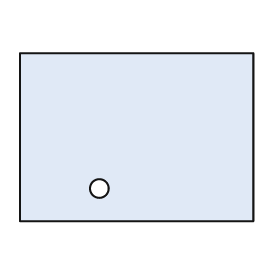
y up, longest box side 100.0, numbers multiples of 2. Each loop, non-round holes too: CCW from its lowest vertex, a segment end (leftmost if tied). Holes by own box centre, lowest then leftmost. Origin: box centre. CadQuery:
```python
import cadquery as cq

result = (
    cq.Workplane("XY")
    .moveTo(-50.0, -36.0)
    .lineTo(50.0, -36.0)
    .lineTo(50.0, 36.0)
    .lineTo(-50.0, 36.0)
    .close()
    .moveTo(-16.0, -22.0)
    .circle(4.0)
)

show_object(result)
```